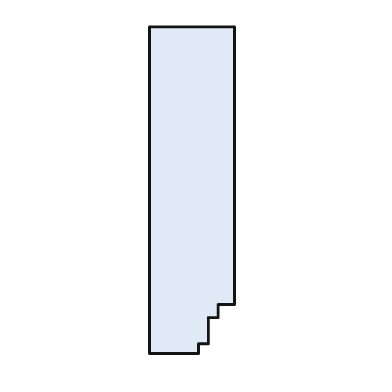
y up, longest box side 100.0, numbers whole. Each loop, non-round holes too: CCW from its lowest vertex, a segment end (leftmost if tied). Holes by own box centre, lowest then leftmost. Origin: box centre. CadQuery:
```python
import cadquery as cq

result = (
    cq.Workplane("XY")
    .moveTo(-13.0, -50.0)
    .lineTo(2.0, -50.0)
    .lineTo(2.0, -47.0)
    .lineTo(5.0, -47.0)
    .lineTo(5.0, -39.0)
    .lineTo(8.0, -39.0)
    .lineTo(8.0, -35.0)
    .lineTo(13.0, -35.0)
    .lineTo(13.0, 50.0)
    .lineTo(-13.0, 50.0)
    .close()
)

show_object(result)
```